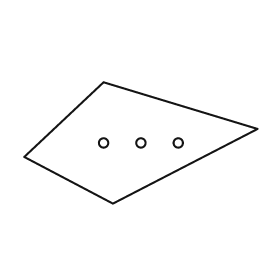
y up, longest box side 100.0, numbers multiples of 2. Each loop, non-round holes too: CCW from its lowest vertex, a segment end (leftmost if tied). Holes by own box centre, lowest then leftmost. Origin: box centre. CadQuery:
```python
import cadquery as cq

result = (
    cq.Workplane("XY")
    .moveTo(-12.0, -26.0)
    .lineTo(50.0, 6.0)
    .lineTo(-16.0, 26.0)
    .lineTo(-50.0, -6.0)
    .close()
    .moveTo(-16.0, 0.0)
    .circle(2.0)
    .moveTo(0.0, 0.0)
    .circle(2.0)
    .moveTo(16.0, 0.0)
    .circle(2.0)
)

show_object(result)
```